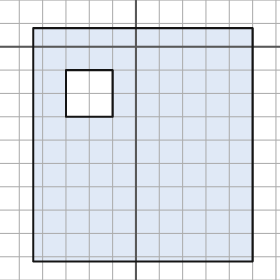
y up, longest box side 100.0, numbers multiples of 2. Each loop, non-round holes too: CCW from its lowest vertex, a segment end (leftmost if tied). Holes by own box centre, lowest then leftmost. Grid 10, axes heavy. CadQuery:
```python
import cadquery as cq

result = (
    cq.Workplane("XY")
    .moveTo(-44.0, -92.0)
    .lineTo(50.0, -92.0)
    .lineTo(50.0, 8.0)
    .lineTo(-44.0, 8.0)
    .close()
    .moveTo(-30.0, -30.0)
    .lineTo(-10.0, -30.0)
    .lineTo(-10.0, -10.0)
    .lineTo(-30.0, -10.0)
    .close()
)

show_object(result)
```